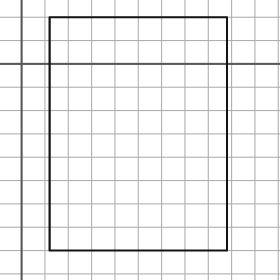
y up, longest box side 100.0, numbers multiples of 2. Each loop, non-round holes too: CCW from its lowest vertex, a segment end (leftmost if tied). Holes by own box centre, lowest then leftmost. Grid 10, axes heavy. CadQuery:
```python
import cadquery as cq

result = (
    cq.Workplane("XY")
    .moveTo(12.0, -80.0)
    .lineTo(88.0, -80.0)
    .lineTo(88.0, 20.0)
    .lineTo(12.0, 20.0)
    .close()
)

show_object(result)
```